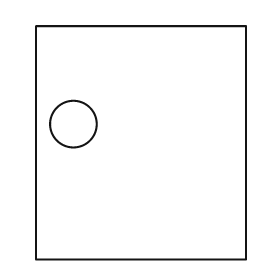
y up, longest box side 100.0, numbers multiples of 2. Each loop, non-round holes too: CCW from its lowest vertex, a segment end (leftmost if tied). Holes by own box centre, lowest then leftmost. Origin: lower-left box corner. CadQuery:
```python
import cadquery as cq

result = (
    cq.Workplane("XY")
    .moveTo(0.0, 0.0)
    .lineTo(90.0, 0.0)
    .lineTo(90.0, 100.0)
    .lineTo(0.0, 100.0)
    .close()
    .moveTo(16.0, 58.0)
    .circle(10.0)
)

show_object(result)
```